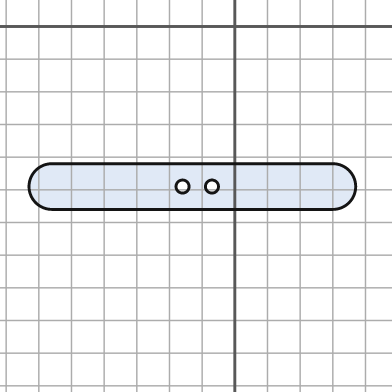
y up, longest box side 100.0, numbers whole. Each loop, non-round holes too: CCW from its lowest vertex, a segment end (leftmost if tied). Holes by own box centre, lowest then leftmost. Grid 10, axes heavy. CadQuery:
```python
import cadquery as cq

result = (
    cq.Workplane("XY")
    .moveTo(-56.0, -56.0)
    .lineTo(30.0, -56.0)
    .threePointArc((37.0, -49.0), (30.0, -42.0))
    .lineTo(-56.0, -42.0)
    .threePointArc((-63.0, -49.0), (-56.0, -56.0))
    .close()
    .moveTo(-16.0, -49.0)
    .circle(2.0)
    .moveTo(-7.0, -49.0)
    .circle(2.0)
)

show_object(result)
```